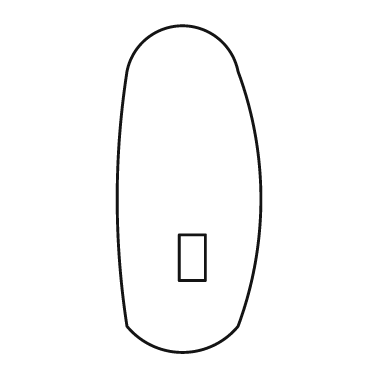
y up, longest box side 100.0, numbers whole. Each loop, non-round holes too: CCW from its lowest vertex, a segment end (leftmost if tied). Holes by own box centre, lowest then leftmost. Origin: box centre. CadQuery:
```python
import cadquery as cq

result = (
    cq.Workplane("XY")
    .moveTo(-19.0, -42.0)
    .threePointArc((-2.0, -50.0), (15.0, -42.0))
    .threePointArc((22.0, -3.0), (15.0, 36.0))
    .threePointArc((-2.0, 50.0), (-19.0, 36.0))
    .threePointArc((-22.0, -3.0), (-19.0, -42.0))
    .close()
    .moveTo(-3.0, -28.0)
    .lineTo(5.0, -28.0)
    .lineTo(5.0, -14.0)
    .lineTo(-3.0, -14.0)
    .close()
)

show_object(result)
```